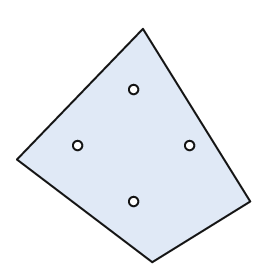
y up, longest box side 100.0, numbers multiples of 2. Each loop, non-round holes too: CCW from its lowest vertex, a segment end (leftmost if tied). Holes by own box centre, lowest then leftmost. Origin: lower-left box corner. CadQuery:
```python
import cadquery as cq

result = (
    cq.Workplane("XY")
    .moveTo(58.0, 0.0)
    .lineTo(100.0, 26.0)
    .lineTo(54.0, 100.0)
    .lineTo(0.0, 44.0)
    .close()
    .moveTo(50.0, 26.0)
    .circle(2.0)
    .moveTo(26.0, 50.0)
    .circle(2.0)
    .moveTo(74.0, 50.0)
    .circle(2.0)
    .moveTo(50.0, 74.0)
    .circle(2.0)
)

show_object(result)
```